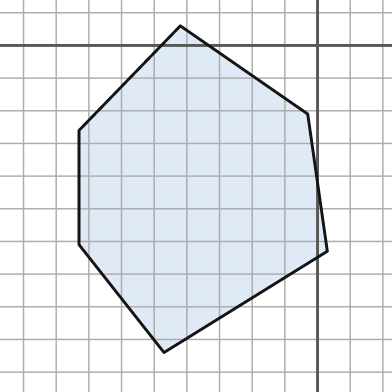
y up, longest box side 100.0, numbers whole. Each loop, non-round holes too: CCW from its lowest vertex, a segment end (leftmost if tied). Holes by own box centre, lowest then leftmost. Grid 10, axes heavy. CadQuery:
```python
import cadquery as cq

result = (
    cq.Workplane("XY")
    .moveTo(-47.0, -94.0)
    .lineTo(3.0, -63.0)
    .lineTo(-3.0, -21.0)
    .lineTo(-42.0, 6.0)
    .lineTo(-73.0, -26.0)
    .lineTo(-73.0, -61.0)
    .close()
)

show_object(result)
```